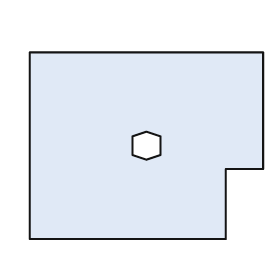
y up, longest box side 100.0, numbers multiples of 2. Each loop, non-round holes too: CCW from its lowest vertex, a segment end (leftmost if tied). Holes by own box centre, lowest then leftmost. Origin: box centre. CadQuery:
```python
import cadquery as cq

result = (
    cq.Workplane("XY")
    .moveTo(-50.0, -40.0)
    .lineTo(34.0, -40.0)
    .lineTo(34.0, -10.0)
    .lineTo(50.0, -10.0)
    .lineTo(50.0, 40.0)
    .lineTo(-50.0, 40.0)
    .close()
    .moveTo(0.0, -6.0)
    .lineTo(6.0, -4.0)
    .lineTo(6.0, 4.0)
    .lineTo(0.0, 6.0)
    .lineTo(-6.0, 4.0)
    .lineTo(-6.0, -4.0)
    .close()
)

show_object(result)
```